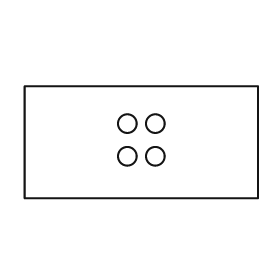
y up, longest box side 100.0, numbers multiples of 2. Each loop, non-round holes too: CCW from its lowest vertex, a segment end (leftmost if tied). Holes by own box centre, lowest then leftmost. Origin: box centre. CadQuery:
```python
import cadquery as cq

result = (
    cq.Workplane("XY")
    .moveTo(-50.0, -24.0)
    .lineTo(50.0, -24.0)
    .lineTo(50.0, 24.0)
    .lineTo(-50.0, 24.0)
    .close()
    .moveTo(-6.0, -6.0)
    .circle(4.0)
    .moveTo(6.0, -6.0)
    .circle(4.0)
    .moveTo(-6.0, 8.0)
    .circle(4.0)
    .moveTo(6.0, 8.0)
    .circle(4.0)
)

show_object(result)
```